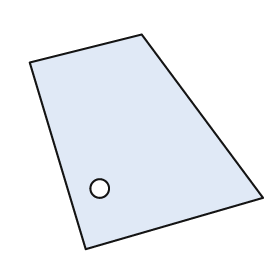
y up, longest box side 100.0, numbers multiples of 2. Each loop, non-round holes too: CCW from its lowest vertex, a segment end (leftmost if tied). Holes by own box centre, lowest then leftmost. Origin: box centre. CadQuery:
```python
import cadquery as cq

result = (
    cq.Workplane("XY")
    .moveTo(-26.0, -46.0)
    .lineTo(50.0, -24.0)
    .lineTo(-2.0, 46.0)
    .lineTo(-50.0, 34.0)
    .close()
    .moveTo(-20.0, -20.0)
    .circle(4.0)
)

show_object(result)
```